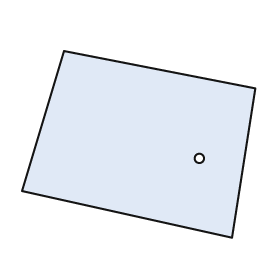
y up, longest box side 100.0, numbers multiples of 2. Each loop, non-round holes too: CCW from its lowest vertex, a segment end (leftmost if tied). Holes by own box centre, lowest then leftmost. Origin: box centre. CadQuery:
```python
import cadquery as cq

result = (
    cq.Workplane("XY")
    .moveTo(40.0, -40.0)
    .lineTo(50.0, 24.0)
    .lineTo(-32.0, 40.0)
    .lineTo(-50.0, -20.0)
    .close()
    .moveTo(26.0, -6.0)
    .circle(2.0)
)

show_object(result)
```